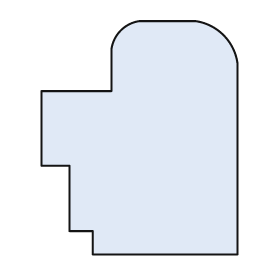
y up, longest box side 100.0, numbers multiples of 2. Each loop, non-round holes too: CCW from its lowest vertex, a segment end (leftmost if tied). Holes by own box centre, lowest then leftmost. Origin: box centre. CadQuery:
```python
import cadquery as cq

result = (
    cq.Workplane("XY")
    .moveTo(-20.0, -50.0)
    .lineTo(42.0, -50.0)
    .lineTo(42.0, 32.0)
    .threePointArc((36.0, 44.0), (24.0, 50.0))
    .lineTo(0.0, 50.0)
    .threePointArc((-8.0, 46.0), (-12.0, 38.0))
    .lineTo(-12.0, 20.0)
    .lineTo(-42.0, 20.0)
    .lineTo(-42.0, -12.0)
    .lineTo(-30.0, -12.0)
    .lineTo(-30.0, -40.0)
    .lineTo(-20.0, -40.0)
    .close()
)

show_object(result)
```